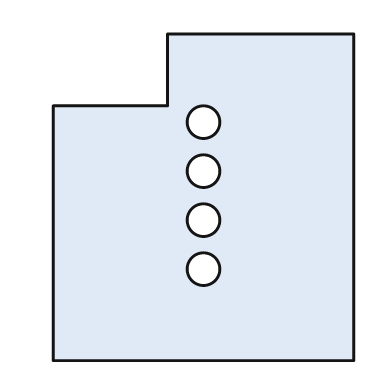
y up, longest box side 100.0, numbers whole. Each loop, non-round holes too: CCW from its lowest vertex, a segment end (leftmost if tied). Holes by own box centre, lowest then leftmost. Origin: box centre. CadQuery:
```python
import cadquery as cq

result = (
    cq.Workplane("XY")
    .moveTo(-46.0, -50.0)
    .lineTo(46.0, -50.0)
    .lineTo(46.0, 50.0)
    .lineTo(-11.0, 50.0)
    .lineTo(-11.0, 28.0)
    .lineTo(-46.0, 28.0)
    .close()
    .moveTo(0.0, -22.0)
    .circle(5.0)
    .moveTo(0.0, -7.0)
    .circle(5.0)
    .moveTo(0.0, 8.0)
    .circle(5.0)
    .moveTo(0.0, 23.0)
    .circle(5.0)
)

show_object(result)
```